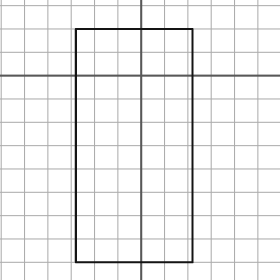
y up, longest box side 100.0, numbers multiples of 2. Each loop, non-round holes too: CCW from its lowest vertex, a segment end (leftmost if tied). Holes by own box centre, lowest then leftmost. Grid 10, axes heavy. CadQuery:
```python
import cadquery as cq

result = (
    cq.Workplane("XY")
    .moveTo(-28.0, -80.0)
    .lineTo(22.0, -80.0)
    .lineTo(22.0, 20.0)
    .lineTo(-28.0, 20.0)
    .close()
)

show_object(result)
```